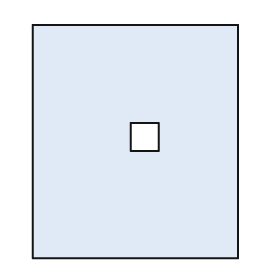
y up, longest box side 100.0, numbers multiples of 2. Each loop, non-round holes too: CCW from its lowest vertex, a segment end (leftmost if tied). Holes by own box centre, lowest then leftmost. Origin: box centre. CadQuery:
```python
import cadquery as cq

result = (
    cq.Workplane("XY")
    .moveTo(-44.0, -50.0)
    .lineTo(44.0, -50.0)
    .lineTo(44.0, 50.0)
    .lineTo(-44.0, 50.0)
    .close()
    .moveTo(-2.0, -4.0)
    .lineTo(10.0, -4.0)
    .lineTo(10.0, 8.0)
    .lineTo(-2.0, 8.0)
    .close()
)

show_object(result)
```